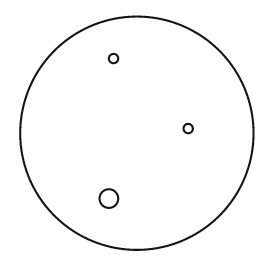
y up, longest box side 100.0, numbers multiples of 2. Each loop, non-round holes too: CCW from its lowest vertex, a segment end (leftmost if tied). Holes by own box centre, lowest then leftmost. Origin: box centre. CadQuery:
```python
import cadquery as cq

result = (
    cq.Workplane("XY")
    .moveTo(0.0, 0.0)
    .circle(50.0)
    .moveTo(-12.0, -28.0)
    .circle(4.0)
    .moveTo(22.0, 2.0)
    .circle(2.0)
    .moveTo(-10.0, 32.0)
    .circle(2.0)
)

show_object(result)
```